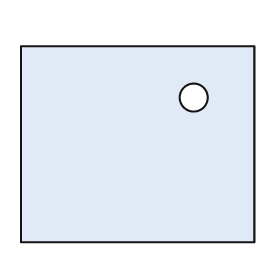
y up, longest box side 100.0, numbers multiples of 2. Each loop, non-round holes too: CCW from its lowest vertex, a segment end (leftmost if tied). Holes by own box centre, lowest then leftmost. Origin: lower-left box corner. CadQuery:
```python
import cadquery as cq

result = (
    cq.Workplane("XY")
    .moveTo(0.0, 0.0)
    .lineTo(100.0, 0.0)
    .lineTo(100.0, 84.0)
    .lineTo(0.0, 84.0)
    .close()
    .moveTo(74.0, 62.0)
    .circle(6.0)
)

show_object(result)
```